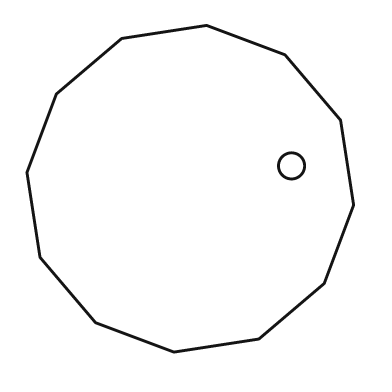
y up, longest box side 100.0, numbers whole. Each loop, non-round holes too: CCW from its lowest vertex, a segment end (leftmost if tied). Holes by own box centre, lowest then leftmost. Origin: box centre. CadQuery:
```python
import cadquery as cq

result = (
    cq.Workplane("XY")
    .moveTo(-5.0, -50.0)
    .lineTo(21.0, -46.0)
    .lineTo(41.0, -29.0)
    .lineTo(50.0, -5.0)
    .lineTo(46.0, 21.0)
    .lineTo(29.0, 41.0)
    .lineTo(5.0, 50.0)
    .lineTo(-21.0, 46.0)
    .lineTo(-41.0, 29.0)
    .lineTo(-50.0, 5.0)
    .lineTo(-46.0, -21.0)
    .lineTo(-29.0, -41.0)
    .close()
    .moveTo(31.0, 7.0)
    .circle(4.0)
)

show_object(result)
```